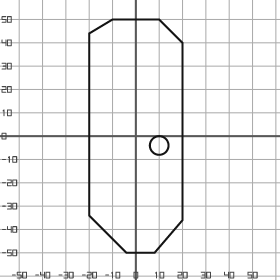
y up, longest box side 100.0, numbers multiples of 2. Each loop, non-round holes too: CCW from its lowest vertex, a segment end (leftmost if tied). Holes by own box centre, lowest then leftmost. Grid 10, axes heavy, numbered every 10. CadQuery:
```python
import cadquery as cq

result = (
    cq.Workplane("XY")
    .moveTo(-4.0, -50.0)
    .lineTo(8.0, -50.0)
    .lineTo(20.0, -36.0)
    .lineTo(20.0, 40.0)
    .lineTo(10.0, 50.0)
    .lineTo(-10.0, 50.0)
    .lineTo(-20.0, 44.0)
    .lineTo(-20.0, -34.0)
    .close()
    .moveTo(10.0, -4.0)
    .circle(4.0)
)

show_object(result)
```